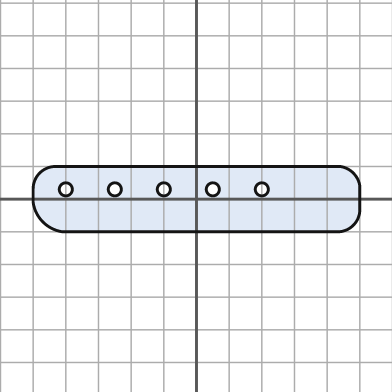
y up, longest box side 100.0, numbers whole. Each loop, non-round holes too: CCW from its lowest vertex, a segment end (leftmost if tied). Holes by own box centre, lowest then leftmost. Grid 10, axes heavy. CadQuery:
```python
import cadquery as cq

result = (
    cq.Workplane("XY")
    .moveTo(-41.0, -10.0)
    .lineTo(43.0, -10.0)
    .threePointArc((48.0, -8.0), (50.0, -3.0))
    .lineTo(50.0, 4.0)
    .threePointArc((48.0, 8.0), (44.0, 10.0))
    .lineTo(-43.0, 10.0)
    .threePointArc((-48.0, 8.0), (-50.0, 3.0))
    .lineTo(-50.0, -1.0)
    .threePointArc((-47.0, -7.0), (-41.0, -10.0))
    .close()
    .moveTo(-40.0, 3.0)
    .circle(2.0)
    .moveTo(-25.0, 3.0)
    .circle(2.0)
    .moveTo(-10.0, 3.0)
    .circle(2.0)
    .moveTo(5.0, 3.0)
    .circle(2.0)
    .moveTo(20.0, 3.0)
    .circle(2.0)
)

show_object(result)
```